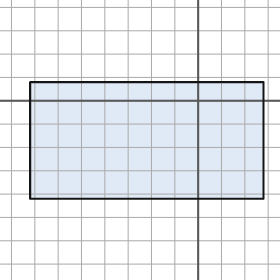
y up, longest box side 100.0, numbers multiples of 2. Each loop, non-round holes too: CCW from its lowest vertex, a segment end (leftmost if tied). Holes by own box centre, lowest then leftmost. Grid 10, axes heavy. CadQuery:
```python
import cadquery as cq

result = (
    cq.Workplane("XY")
    .moveTo(-72.0, -42.0)
    .lineTo(28.0, -42.0)
    .lineTo(28.0, 8.0)
    .lineTo(-72.0, 8.0)
    .close()
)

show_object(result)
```